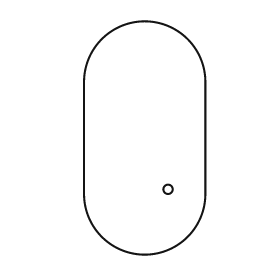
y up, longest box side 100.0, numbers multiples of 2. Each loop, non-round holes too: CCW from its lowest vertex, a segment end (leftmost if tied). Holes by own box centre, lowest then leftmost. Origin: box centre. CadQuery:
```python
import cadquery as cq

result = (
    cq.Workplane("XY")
    .moveTo(-26.0, -24.0)
    .threePointArc((0.0, -50.0), (26.0, -24.0))
    .lineTo(26.0, 24.0)
    .threePointArc((0.0, 50.0), (-26.0, 24.0))
    .close()
    .moveTo(10.0, -22.0)
    .circle(2.0)
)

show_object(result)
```